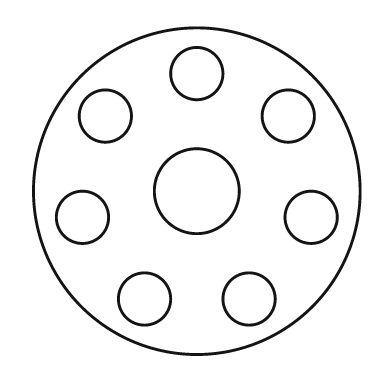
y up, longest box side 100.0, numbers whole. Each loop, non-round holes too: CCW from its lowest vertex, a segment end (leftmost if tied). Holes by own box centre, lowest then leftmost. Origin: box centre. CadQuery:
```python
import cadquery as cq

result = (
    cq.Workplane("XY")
    .moveTo(0.0, 0.0)
    .circle(50.0)
    .moveTo(-16.0, -33.0)
    .circle(8.0)
    .moveTo(16.0, -33.0)
    .circle(8.0)
    .moveTo(-35.0, -8.0)
    .circle(8.0)
    .moveTo(35.0, -8.0)
    .circle(8.0)
    .moveTo(0.0, 0.0)
    .circle(13.0)
    .moveTo(-28.0, 23.0)
    .circle(8.0)
    .moveTo(28.0, 23.0)
    .circle(8.0)
    .moveTo(0.0, 36.0)
    .circle(8.0)
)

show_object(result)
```